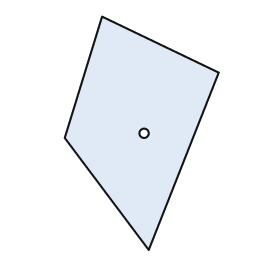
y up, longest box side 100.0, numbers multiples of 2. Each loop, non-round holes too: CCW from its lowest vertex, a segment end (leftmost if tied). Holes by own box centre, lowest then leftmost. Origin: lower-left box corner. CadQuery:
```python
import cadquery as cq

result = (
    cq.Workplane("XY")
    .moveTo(36.0, 0.0)
    .lineTo(66.0, 76.0)
    .lineTo(16.0, 100.0)
    .lineTo(0.0, 48.0)
    .close()
    .moveTo(34.0, 50.0)
    .circle(2.0)
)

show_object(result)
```